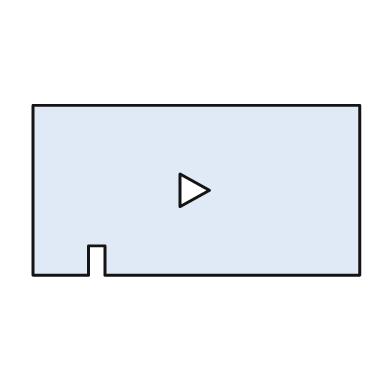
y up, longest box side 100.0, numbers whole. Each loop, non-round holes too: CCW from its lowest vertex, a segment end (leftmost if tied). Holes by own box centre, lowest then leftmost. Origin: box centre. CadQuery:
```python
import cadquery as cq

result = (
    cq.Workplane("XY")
    .moveTo(-50.0, -26.0)
    .lineTo(-33.0, -26.0)
    .lineTo(-33.0, -17.0)
    .lineTo(-28.0, -17.0)
    .lineTo(-28.0, -26.0)
    .lineTo(50.0, -26.0)
    .lineTo(50.0, 26.0)
    .lineTo(-50.0, 26.0)
    .close()
    .moveTo(-5.0, -5.0)
    .lineTo(4.0, 0.0)
    .lineTo(-5.0, 5.0)
    .close()
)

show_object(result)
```